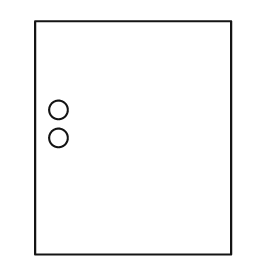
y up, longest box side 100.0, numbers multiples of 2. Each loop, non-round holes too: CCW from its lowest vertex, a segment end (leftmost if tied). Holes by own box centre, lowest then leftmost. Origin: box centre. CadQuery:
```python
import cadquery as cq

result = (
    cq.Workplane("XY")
    .moveTo(-42.0, -50.0)
    .lineTo(42.0, -50.0)
    .lineTo(42.0, 50.0)
    .lineTo(-42.0, 50.0)
    .close()
    .moveTo(-32.0, 0.0)
    .circle(4.0)
    .moveTo(-32.0, 12.0)
    .circle(4.0)
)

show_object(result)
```